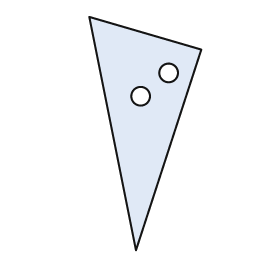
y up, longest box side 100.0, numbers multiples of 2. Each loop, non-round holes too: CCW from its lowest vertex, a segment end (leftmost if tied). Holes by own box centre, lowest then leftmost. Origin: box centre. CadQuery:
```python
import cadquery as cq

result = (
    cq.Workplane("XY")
    .moveTo(-4.0, -50.0)
    .lineTo(24.0, 36.0)
    .lineTo(-24.0, 50.0)
    .close()
    .moveTo(-2.0, 16.0)
    .circle(4.0)
    .moveTo(10.0, 26.0)
    .circle(4.0)
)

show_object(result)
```